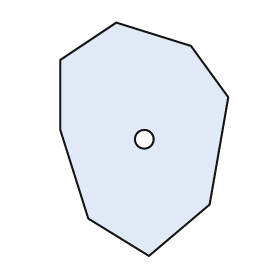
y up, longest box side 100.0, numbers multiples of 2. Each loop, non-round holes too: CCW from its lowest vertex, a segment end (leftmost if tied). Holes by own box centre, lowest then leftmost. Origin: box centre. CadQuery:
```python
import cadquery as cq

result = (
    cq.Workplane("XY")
    .moveTo(2.0, -50.0)
    .lineTo(28.0, -28.0)
    .lineTo(36.0, 18.0)
    .lineTo(20.0, 40.0)
    .lineTo(-12.0, 50.0)
    .lineTo(-36.0, 34.0)
    .lineTo(-36.0, 4.0)
    .lineTo(-24.0, -34.0)
    .close()
    .moveTo(0.0, 0.0)
    .circle(4.0)
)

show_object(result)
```